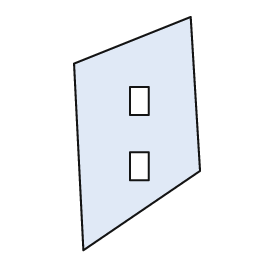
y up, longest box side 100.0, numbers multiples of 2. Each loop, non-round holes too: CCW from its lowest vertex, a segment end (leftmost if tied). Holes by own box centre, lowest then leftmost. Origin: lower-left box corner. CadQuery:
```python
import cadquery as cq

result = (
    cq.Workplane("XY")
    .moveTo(4.0, 0.0)
    .lineTo(54.0, 34.0)
    .lineTo(50.0, 100.0)
    .lineTo(0.0, 80.0)
    .close()
    .moveTo(24.0, 30.0)
    .lineTo(32.0, 30.0)
    .lineTo(32.0, 42.0)
    .lineTo(24.0, 42.0)
    .close()
    .moveTo(24.0, 58.0)
    .lineTo(32.0, 58.0)
    .lineTo(32.0, 70.0)
    .lineTo(24.0, 70.0)
    .close()
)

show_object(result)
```